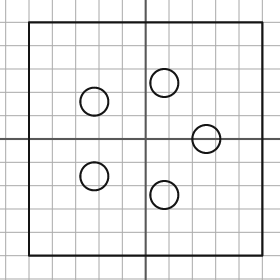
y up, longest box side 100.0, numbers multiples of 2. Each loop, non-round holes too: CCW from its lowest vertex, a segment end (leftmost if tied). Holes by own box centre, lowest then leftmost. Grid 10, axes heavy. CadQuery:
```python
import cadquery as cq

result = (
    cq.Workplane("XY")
    .moveTo(-50.0, -50.0)
    .lineTo(50.0, -50.0)
    .lineTo(50.0, 50.0)
    .lineTo(-50.0, 50.0)
    .close()
    .moveTo(8.0, -24.0)
    .circle(6.0)
    .moveTo(-22.0, -16.0)
    .circle(6.0)
    .moveTo(26.0, 0.0)
    .circle(6.0)
    .moveTo(-22.0, 16.0)
    .circle(6.0)
    .moveTo(8.0, 24.0)
    .circle(6.0)
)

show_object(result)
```